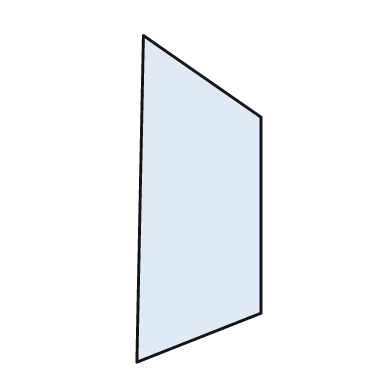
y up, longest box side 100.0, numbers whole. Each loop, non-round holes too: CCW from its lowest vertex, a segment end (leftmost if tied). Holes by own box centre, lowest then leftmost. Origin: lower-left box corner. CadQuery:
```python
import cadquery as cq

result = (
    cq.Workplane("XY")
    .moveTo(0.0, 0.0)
    .lineTo(38.0, 15.0)
    .lineTo(38.0, 75.0)
    .lineTo(2.0, 100.0)
    .close()
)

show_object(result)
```